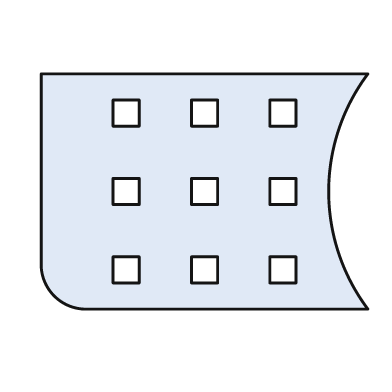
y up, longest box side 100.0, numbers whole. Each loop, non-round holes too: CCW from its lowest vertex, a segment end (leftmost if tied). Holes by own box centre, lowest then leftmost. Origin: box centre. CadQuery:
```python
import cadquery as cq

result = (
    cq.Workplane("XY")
    .moveTo(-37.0, -36.0)
    .lineTo(50.0, -36.0)
    .threePointArc((38.0, 0.0), (50.0, 36.0))
    .lineTo(-50.0, 36.0)
    .lineTo(-50.0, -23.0)
    .threePointArc((-46.0, -32.0), (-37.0, -36.0))
    .close()
    .moveTo(-28.0, -28.0)
    .lineTo(-20.0, -28.0)
    .lineTo(-20.0, -20.0)
    .lineTo(-28.0, -20.0)
    .close()
    .moveTo(-4.0, -28.0)
    .lineTo(4.0, -28.0)
    .lineTo(4.0, -20.0)
    .lineTo(-4.0, -20.0)
    .close()
    .moveTo(20.0, -28.0)
    .lineTo(28.0, -28.0)
    .lineTo(28.0, -20.0)
    .lineTo(20.0, -20.0)
    .close()
    .moveTo(-28.0, -4.0)
    .lineTo(-20.0, -4.0)
    .lineTo(-20.0, 4.0)
    .lineTo(-28.0, 4.0)
    .close()
    .moveTo(-4.0, -4.0)
    .lineTo(4.0, -4.0)
    .lineTo(4.0, 4.0)
    .lineTo(-4.0, 4.0)
    .close()
    .moveTo(20.0, -4.0)
    .lineTo(28.0, -4.0)
    .lineTo(28.0, 4.0)
    .lineTo(20.0, 4.0)
    .close()
    .moveTo(-28.0, 20.0)
    .lineTo(-20.0, 20.0)
    .lineTo(-20.0, 28.0)
    .lineTo(-28.0, 28.0)
    .close()
    .moveTo(-4.0, 20.0)
    .lineTo(4.0, 20.0)
    .lineTo(4.0, 28.0)
    .lineTo(-4.0, 28.0)
    .close()
    .moveTo(20.0, 20.0)
    .lineTo(28.0, 20.0)
    .lineTo(28.0, 28.0)
    .lineTo(20.0, 28.0)
    .close()
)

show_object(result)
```